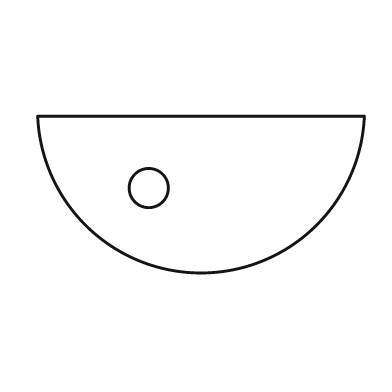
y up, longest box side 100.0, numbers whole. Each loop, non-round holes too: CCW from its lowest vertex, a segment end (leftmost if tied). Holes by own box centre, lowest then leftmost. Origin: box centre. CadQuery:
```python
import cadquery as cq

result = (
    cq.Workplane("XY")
    .moveTo(-50.0, 24.0)
    .threePointArc((0.0, -24.0), (50.0, 24.0))
    .close()
    .moveTo(-16.0, 2.0)
    .circle(6.0)
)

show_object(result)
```